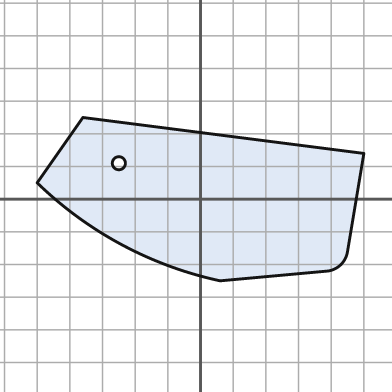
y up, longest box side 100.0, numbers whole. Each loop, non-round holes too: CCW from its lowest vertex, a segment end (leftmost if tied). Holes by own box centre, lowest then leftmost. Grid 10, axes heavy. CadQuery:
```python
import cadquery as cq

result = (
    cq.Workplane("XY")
    .moveTo(6.0, -25.0)
    .lineTo(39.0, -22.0)
    .threePointArc((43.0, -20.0), (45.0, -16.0))
    .lineTo(50.0, 14.0)
    .lineTo(-36.0, 25.0)
    .lineTo(-50.0, 5.0)
    .threePointArc((-24.0, -14.0), (6.0, -25.0))
    .close()
    .moveTo(-25.0, 11.0)
    .circle(2.0)
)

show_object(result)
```